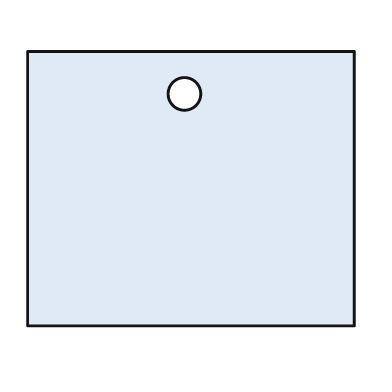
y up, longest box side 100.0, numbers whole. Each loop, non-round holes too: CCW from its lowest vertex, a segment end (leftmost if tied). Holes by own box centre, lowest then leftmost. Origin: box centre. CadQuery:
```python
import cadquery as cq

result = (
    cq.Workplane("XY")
    .moveTo(-50.0, -42.0)
    .lineTo(50.0, -42.0)
    .lineTo(50.0, 42.0)
    .lineTo(-50.0, 42.0)
    .close()
    .moveTo(-2.0, 29.0)
    .circle(5.0)
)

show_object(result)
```